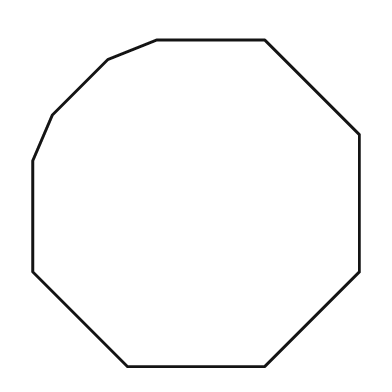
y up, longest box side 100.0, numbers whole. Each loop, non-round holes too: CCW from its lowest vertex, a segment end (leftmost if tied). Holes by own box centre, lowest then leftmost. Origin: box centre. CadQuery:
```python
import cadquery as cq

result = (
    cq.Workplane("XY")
    .moveTo(-21.0, -50.0)
    .lineTo(21.0, -50.0)
    .lineTo(50.0, -21.0)
    .lineTo(50.0, 21.0)
    .lineTo(21.0, 50.0)
    .lineTo(-12.0, 50.0)
    .lineTo(-27.0, 44.0)
    .lineTo(-44.0, 27.0)
    .lineTo(-50.0, 13.0)
    .lineTo(-50.0, -21.0)
    .close()
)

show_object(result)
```